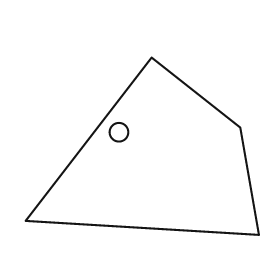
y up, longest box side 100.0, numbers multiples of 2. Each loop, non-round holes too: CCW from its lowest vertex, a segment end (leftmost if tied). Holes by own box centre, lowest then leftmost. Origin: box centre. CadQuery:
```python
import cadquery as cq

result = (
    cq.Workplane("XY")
    .moveTo(50.0, -38.0)
    .lineTo(42.0, 8.0)
    .lineTo(4.0, 38.0)
    .lineTo(-50.0, -32.0)
    .close()
    .moveTo(-10.0, 6.0)
    .circle(4.0)
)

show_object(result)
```